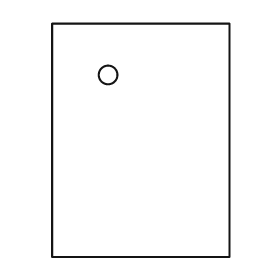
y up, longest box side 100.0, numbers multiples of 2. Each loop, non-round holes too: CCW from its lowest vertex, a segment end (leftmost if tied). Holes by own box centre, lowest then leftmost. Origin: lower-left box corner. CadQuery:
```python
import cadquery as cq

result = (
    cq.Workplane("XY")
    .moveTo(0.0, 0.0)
    .lineTo(76.0, 0.0)
    .lineTo(76.0, 100.0)
    .lineTo(0.0, 100.0)
    .close()
    .moveTo(24.0, 78.0)
    .circle(4.0)
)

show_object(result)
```